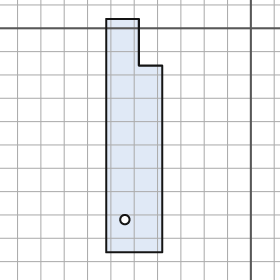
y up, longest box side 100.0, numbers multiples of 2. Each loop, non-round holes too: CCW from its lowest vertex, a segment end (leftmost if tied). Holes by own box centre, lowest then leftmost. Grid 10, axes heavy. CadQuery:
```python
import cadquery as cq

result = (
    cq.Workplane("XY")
    .moveTo(-62.0, -96.0)
    .lineTo(-38.0, -96.0)
    .lineTo(-38.0, -16.0)
    .lineTo(-48.0, -16.0)
    .lineTo(-48.0, 4.0)
    .lineTo(-62.0, 4.0)
    .close()
    .moveTo(-54.0, -82.0)
    .circle(2.0)
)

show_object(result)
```